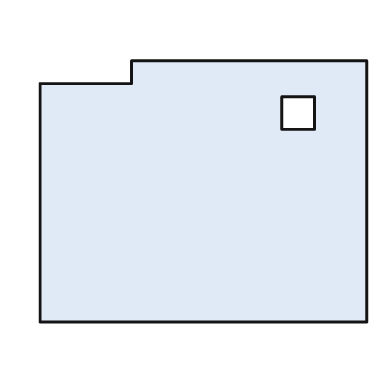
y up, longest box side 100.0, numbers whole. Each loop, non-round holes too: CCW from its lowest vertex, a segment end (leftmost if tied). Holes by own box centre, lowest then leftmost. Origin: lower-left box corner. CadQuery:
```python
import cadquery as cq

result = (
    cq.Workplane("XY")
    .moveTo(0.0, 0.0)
    .lineTo(100.0, 0.0)
    .lineTo(100.0, 80.0)
    .lineTo(28.0, 80.0)
    .lineTo(28.0, 73.0)
    .lineTo(0.0, 73.0)
    .close()
    .moveTo(74.0, 59.0)
    .lineTo(84.0, 59.0)
    .lineTo(84.0, 69.0)
    .lineTo(74.0, 69.0)
    .close()
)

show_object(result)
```